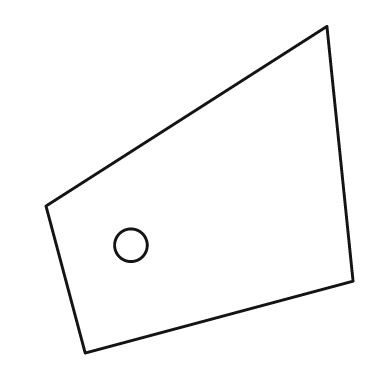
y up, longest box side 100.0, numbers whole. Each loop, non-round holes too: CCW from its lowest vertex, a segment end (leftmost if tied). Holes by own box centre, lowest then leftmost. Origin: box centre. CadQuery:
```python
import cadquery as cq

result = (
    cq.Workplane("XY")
    .moveTo(-35.0, -50.0)
    .lineTo(47.0, -28.0)
    .lineTo(39.0, 50.0)
    .lineTo(-47.0, -5.0)
    .close()
    .moveTo(-21.0, -17.0)
    .circle(5.0)
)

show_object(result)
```